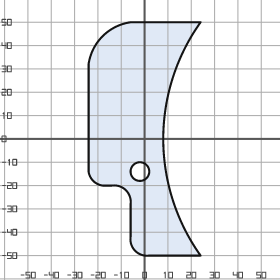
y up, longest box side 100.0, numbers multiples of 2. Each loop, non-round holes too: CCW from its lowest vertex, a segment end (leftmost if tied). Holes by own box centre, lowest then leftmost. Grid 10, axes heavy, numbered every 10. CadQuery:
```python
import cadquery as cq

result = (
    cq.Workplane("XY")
    .moveTo(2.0, -50.0)
    .lineTo(24.0, -50.0)
    .threePointArc((8.0, 0.0), (24.0, 50.0))
    .lineTo(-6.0, 50.0)
    .threePointArc((-18.0, 44.0), (-24.0, 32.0))
    .lineTo(-24.0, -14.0)
    .threePointArc((-22.0, -18.0), (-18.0, -20.0))
    .lineTo(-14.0, -20.0)
    .threePointArc((-8.0, -22.0), (-6.0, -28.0))
    .lineTo(-6.0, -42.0)
    .threePointArc((-4.0, -48.0), (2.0, -50.0))
    .close()
    .moveTo(-2.0, -14.0)
    .circle(4.0)
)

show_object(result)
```